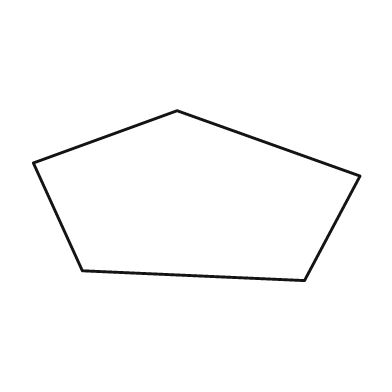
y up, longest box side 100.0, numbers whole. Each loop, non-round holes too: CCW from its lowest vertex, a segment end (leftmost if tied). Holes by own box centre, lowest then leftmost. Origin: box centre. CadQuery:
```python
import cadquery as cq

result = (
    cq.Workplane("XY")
    .moveTo(33.0, -26.0)
    .lineTo(50.0, 6.0)
    .lineTo(-6.0, 26.0)
    .lineTo(-50.0, 10.0)
    .lineTo(-35.0, -23.0)
    .close()
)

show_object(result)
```